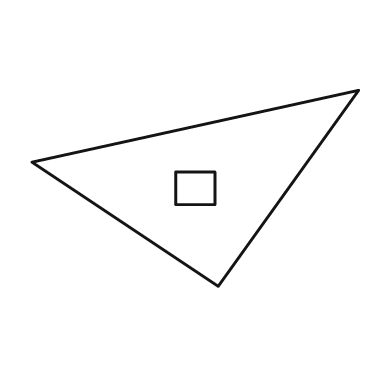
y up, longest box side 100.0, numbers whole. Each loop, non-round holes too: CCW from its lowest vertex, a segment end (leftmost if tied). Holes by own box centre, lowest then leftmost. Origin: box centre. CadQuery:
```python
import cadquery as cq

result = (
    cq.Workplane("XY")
    .moveTo(7.0, -30.0)
    .lineTo(50.0, 30.0)
    .lineTo(-50.0, 8.0)
    .close()
    .moveTo(-6.0, -5.0)
    .lineTo(6.0, -5.0)
    .lineTo(6.0, 5.0)
    .lineTo(-6.0, 5.0)
    .close()
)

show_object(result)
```